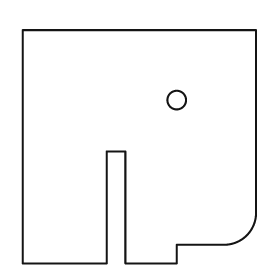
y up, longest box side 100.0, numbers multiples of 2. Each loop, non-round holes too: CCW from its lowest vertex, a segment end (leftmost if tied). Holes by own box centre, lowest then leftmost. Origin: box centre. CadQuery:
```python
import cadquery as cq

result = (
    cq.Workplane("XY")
    .moveTo(-50.0, -50.0)
    .lineTo(-14.0, -50.0)
    .lineTo(-14.0, -2.0)
    .lineTo(-6.0, -2.0)
    .lineTo(-6.0, -50.0)
    .lineTo(16.0, -50.0)
    .lineTo(16.0, -42.0)
    .lineTo(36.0, -42.0)
    .threePointArc((46.0, -38.0), (50.0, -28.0))
    .lineTo(50.0, 50.0)
    .lineTo(-50.0, 50.0)
    .close()
    .moveTo(16.0, 20.0)
    .circle(4.0)
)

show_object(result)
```